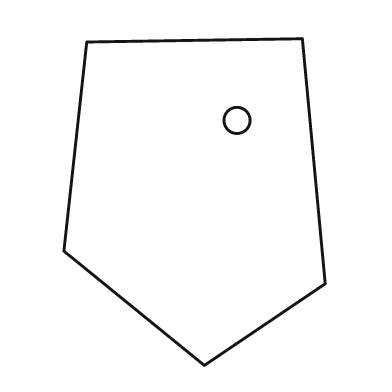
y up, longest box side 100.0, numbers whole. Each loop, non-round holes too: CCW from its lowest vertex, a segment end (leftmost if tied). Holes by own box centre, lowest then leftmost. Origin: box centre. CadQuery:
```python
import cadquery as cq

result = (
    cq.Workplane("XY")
    .moveTo(3.0, -50.0)
    .lineTo(40.0, -25.0)
    .lineTo(33.0, 50.0)
    .lineTo(-33.0, 49.0)
    .lineTo(-40.0, -15.0)
    .close()
    .moveTo(13.0, 25.0)
    .circle(4.0)
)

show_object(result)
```